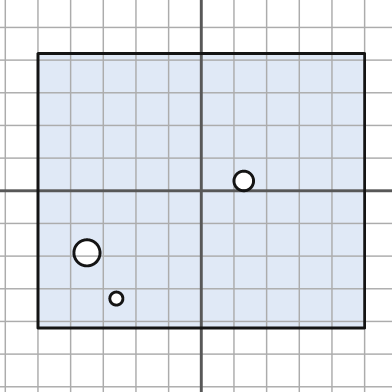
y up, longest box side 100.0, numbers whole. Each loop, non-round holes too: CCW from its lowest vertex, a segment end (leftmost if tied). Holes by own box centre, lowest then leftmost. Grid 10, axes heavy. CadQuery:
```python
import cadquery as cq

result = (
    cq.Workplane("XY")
    .moveTo(-50.0, -42.0)
    .lineTo(50.0, -42.0)
    .lineTo(50.0, 42.0)
    .lineTo(-50.0, 42.0)
    .close()
    .moveTo(-26.0, -33.0)
    .circle(2.0)
    .moveTo(-35.0, -19.0)
    .circle(4.0)
    .moveTo(13.0, 3.0)
    .circle(3.0)
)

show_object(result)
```